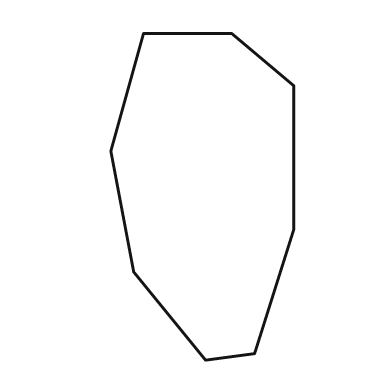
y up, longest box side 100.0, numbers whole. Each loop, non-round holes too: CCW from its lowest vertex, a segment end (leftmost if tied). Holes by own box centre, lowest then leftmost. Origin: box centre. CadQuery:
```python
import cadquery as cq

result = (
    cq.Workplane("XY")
    .moveTo(1.0, -50.0)
    .lineTo(16.0, -48.0)
    .lineTo(28.0, -10.0)
    .lineTo(28.0, 34.0)
    .lineTo(9.0, 50.0)
    .lineTo(-18.0, 50.0)
    .lineTo(-28.0, 14.0)
    .lineTo(-21.0, -23.0)
    .close()
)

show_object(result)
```